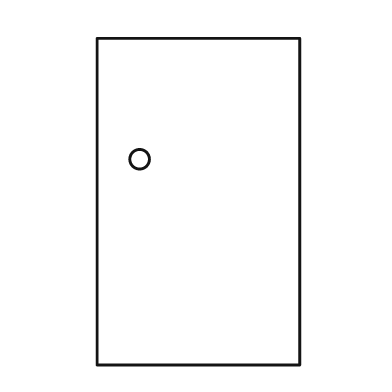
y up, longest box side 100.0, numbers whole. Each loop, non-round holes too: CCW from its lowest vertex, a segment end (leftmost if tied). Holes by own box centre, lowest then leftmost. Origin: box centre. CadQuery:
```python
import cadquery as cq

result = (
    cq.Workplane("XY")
    .moveTo(-31.0, -50.0)
    .lineTo(31.0, -50.0)
    .lineTo(31.0, 50.0)
    .lineTo(-31.0, 50.0)
    .close()
    .moveTo(-18.0, 13.0)
    .circle(3.0)
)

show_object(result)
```